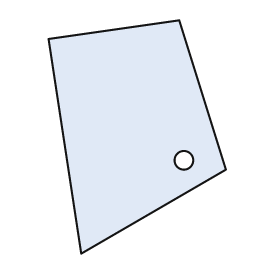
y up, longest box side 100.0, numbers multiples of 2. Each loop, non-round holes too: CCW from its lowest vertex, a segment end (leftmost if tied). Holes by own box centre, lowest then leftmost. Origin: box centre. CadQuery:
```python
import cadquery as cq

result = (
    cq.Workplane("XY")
    .moveTo(-24.0, -50.0)
    .lineTo(38.0, -14.0)
    .lineTo(18.0, 50.0)
    .lineTo(-38.0, 42.0)
    .close()
    .moveTo(20.0, -10.0)
    .circle(4.0)
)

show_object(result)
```